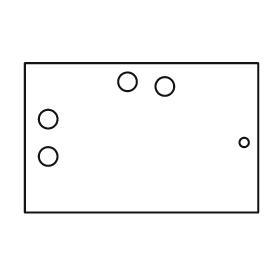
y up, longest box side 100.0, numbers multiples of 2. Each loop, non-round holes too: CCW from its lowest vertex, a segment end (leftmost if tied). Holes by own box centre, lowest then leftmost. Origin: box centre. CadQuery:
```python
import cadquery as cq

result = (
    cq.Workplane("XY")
    .moveTo(-50.0, -32.0)
    .lineTo(50.0, -32.0)
    .lineTo(50.0, 32.0)
    .lineTo(-50.0, 32.0)
    .close()
    .moveTo(-40.0, -8.0)
    .circle(4.0)
    .moveTo(44.0, -2.0)
    .circle(2.0)
    .moveTo(-40.0, 8.0)
    .circle(4.0)
    .moveTo(10.0, 22.0)
    .circle(4.0)
    .moveTo(-6.0, 24.0)
    .circle(4.0)
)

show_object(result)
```